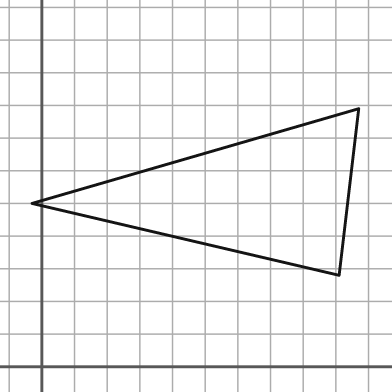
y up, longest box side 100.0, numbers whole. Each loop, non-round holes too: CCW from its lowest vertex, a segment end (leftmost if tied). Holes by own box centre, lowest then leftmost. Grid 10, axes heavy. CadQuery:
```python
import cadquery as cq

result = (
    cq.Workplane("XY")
    .moveTo(91.0, 28.0)
    .lineTo(97.0, 79.0)
    .lineTo(-3.0, 50.0)
    .close()
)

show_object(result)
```